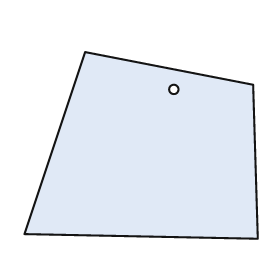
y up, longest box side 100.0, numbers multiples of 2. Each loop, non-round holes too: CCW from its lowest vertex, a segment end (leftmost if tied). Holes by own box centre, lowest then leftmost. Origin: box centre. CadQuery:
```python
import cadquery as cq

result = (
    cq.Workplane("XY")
    .moveTo(50.0, -40.0)
    .lineTo(48.0, 26.0)
    .lineTo(-24.0, 40.0)
    .lineTo(-50.0, -38.0)
    .close()
    .moveTo(14.0, 24.0)
    .circle(2.0)
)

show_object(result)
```